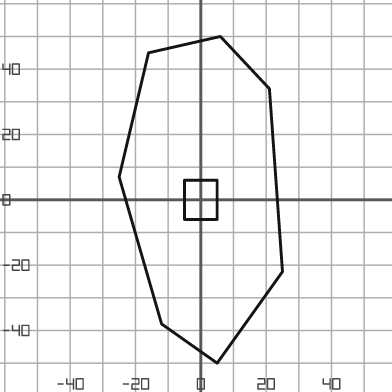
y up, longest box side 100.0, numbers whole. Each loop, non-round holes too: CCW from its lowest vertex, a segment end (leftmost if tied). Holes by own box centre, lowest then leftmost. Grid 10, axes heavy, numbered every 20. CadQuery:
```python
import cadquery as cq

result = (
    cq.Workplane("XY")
    .moveTo(5.0, -50.0)
    .lineTo(25.0, -22.0)
    .lineTo(21.0, 34.0)
    .lineTo(6.0, 50.0)
    .lineTo(-16.0, 45.0)
    .lineTo(-25.0, 7.0)
    .lineTo(-12.0, -38.0)
    .close()
    .moveTo(-5.0, -6.0)
    .lineTo(5.0, -6.0)
    .lineTo(5.0, 6.0)
    .lineTo(-5.0, 6.0)
    .close()
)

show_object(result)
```